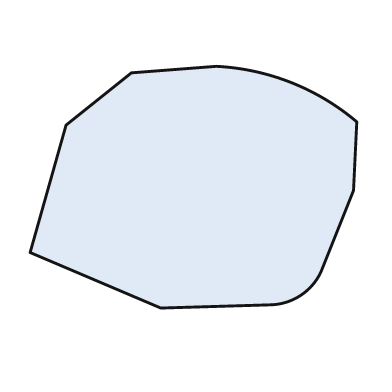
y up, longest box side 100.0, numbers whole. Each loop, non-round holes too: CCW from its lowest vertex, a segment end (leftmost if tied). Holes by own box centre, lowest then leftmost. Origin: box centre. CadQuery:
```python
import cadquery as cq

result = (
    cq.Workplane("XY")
    .moveTo(-10.0, -37.0)
    .lineTo(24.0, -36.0)
    .threePointArc((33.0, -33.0), (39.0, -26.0))
    .lineTo(49.0, -1.0)
    .lineTo(50.0, 20.0)
    .threePointArc((30.0, 32.0), (7.0, 37.0))
    .lineTo(-19.0, 35.0)
    .lineTo(-39.0, 19.0)
    .lineTo(-50.0, -20.0)
    .close()
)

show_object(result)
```